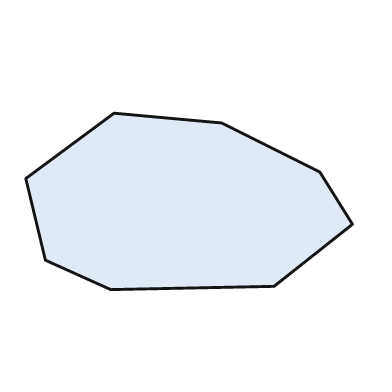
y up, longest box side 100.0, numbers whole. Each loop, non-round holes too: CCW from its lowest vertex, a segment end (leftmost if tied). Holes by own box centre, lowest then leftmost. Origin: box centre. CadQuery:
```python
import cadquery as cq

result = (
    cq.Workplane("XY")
    .moveTo(-24.0, -27.0)
    .lineTo(26.0, -26.0)
    .lineTo(50.0, -7.0)
    .lineTo(40.0, 9.0)
    .lineTo(10.0, 24.0)
    .lineTo(-23.0, 27.0)
    .lineTo(-50.0, 7.0)
    .lineTo(-44.0, -18.0)
    .close()
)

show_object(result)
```